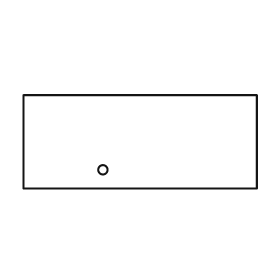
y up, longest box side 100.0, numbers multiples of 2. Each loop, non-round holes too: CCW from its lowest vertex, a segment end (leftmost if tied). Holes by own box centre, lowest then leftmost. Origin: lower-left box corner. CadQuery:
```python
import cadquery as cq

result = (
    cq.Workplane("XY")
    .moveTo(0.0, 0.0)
    .lineTo(100.0, 0.0)
    .lineTo(100.0, 40.0)
    .lineTo(0.0, 40.0)
    .close()
    .moveTo(34.0, 8.0)
    .circle(2.0)
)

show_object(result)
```